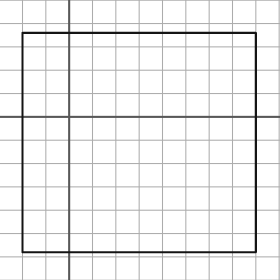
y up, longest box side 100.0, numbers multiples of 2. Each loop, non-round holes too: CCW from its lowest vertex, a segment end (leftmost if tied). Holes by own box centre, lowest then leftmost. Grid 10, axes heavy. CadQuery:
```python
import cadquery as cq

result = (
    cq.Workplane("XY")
    .moveTo(-20.0, -58.0)
    .lineTo(80.0, -58.0)
    .lineTo(80.0, 36.0)
    .lineTo(-20.0, 36.0)
    .close()
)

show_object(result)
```